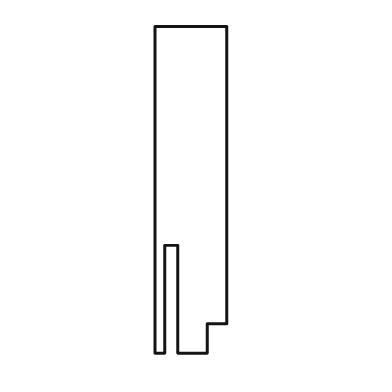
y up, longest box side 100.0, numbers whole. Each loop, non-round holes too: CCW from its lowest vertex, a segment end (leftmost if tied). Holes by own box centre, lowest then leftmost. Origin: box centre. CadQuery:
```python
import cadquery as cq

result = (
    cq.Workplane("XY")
    .moveTo(-11.0, -50.0)
    .lineTo(-8.0, -50.0)
    .lineTo(-8.0, -17.0)
    .lineTo(-4.0, -17.0)
    .lineTo(-4.0, -50.0)
    .lineTo(5.0, -50.0)
    .lineTo(5.0, -41.0)
    .lineTo(11.0, -41.0)
    .lineTo(11.0, 50.0)
    .lineTo(-11.0, 50.0)
    .close()
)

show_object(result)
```